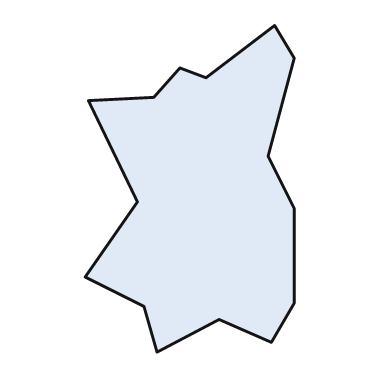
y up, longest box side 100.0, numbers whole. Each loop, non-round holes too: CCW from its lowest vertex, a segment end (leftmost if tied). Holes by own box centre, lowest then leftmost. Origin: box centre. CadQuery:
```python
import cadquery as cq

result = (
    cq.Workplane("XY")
    .moveTo(-10.0, -50.0)
    .lineTo(9.0, -40.0)
    .lineTo(25.0, -47.0)
    .lineTo(32.0, -35.0)
    .lineTo(32.0, -6.0)
    .lineTo(24.0, 10.0)
    .lineTo(32.0, 40.0)
    .lineTo(26.0, 50.0)
    .lineTo(5.0, 34.0)
    .lineTo(-3.0, 37.0)
    .lineTo(-11.0, 28.0)
    .lineTo(-31.0, 27.0)
    .lineTo(-16.0, -4.0)
    .lineTo(-32.0, -27.0)
    .lineTo(-14.0, -36.0)
    .close()
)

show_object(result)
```